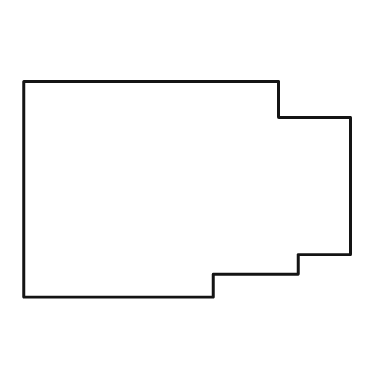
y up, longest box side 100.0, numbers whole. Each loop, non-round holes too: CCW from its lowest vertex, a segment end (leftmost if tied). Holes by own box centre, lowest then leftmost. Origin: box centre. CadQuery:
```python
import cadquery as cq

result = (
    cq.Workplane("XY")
    .moveTo(-50.0, -33.0)
    .lineTo(8.0, -33.0)
    .lineTo(8.0, -26.0)
    .lineTo(34.0, -26.0)
    .lineTo(34.0, -20.0)
    .lineTo(50.0, -20.0)
    .lineTo(50.0, 22.0)
    .lineTo(28.0, 22.0)
    .lineTo(28.0, 33.0)
    .lineTo(-50.0, 33.0)
    .close()
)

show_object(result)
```